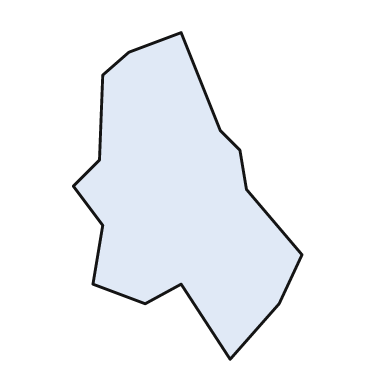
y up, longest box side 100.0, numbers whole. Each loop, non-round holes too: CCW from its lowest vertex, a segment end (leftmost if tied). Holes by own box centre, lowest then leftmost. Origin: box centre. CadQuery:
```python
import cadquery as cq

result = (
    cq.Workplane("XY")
    .moveTo(13.0, -50.0)
    .lineTo(28.0, -33.0)
    .lineTo(35.0, -18.0)
    .lineTo(18.0, 2.0)
    .lineTo(16.0, 14.0)
    .lineTo(10.0, 20.0)
    .lineTo(-2.0, 50.0)
    .lineTo(-18.0, 44.0)
    .lineTo(-26.0, 37.0)
    .lineTo(-27.0, 11.0)
    .lineTo(-35.0, 3.0)
    .lineTo(-26.0, -9.0)
    .lineTo(-29.0, -27.0)
    .lineTo(-13.0, -33.0)
    .lineTo(-2.0, -27.0)
    .close()
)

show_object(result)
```